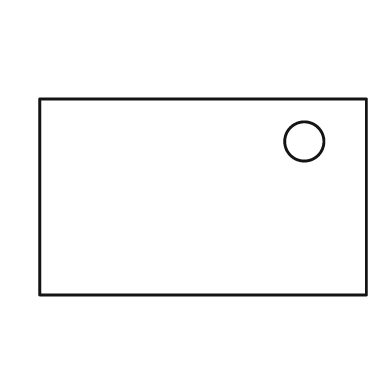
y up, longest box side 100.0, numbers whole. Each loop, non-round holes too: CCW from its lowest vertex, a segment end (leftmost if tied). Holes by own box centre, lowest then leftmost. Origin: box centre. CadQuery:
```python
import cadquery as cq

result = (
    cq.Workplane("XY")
    .moveTo(-50.0, -30.0)
    .lineTo(50.0, -30.0)
    .lineTo(50.0, 30.0)
    .lineTo(-50.0, 30.0)
    .close()
    .moveTo(31.0, 17.0)
    .circle(6.0)
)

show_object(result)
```